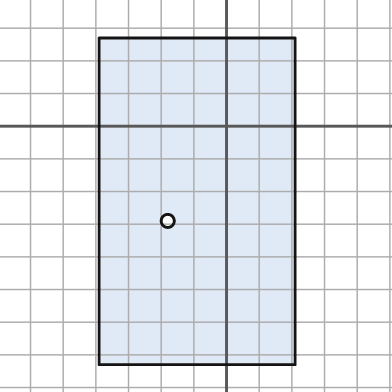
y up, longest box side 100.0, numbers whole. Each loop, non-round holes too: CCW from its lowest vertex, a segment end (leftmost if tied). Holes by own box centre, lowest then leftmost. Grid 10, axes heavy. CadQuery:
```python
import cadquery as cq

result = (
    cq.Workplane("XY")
    .moveTo(-39.0, -73.0)
    .lineTo(21.0, -73.0)
    .lineTo(21.0, 27.0)
    .lineTo(-39.0, 27.0)
    .close()
    .moveTo(-18.0, -29.0)
    .circle(2.0)
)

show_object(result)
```